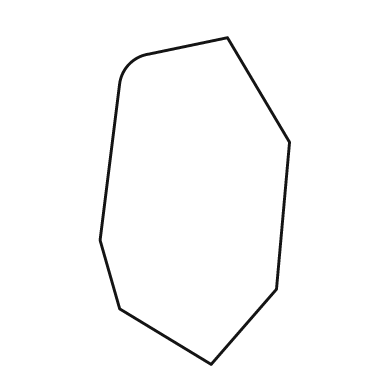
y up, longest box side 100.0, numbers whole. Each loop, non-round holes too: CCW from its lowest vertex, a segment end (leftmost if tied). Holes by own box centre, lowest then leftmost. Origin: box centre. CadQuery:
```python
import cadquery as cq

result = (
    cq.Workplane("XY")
    .moveTo(5.0, -50.0)
    .lineTo(25.0, -27.0)
    .lineTo(29.0, 18.0)
    .lineTo(10.0, 50.0)
    .lineTo(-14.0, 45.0)
    .threePointArc((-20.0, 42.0), (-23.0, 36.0))
    .lineTo(-29.0, -12.0)
    .lineTo(-23.0, -33.0)
    .close()
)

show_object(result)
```